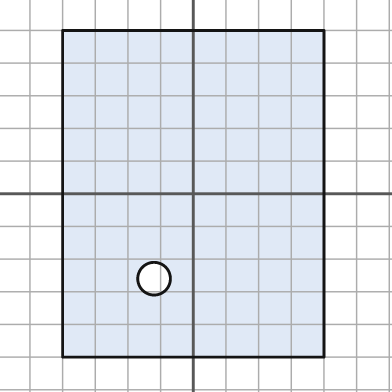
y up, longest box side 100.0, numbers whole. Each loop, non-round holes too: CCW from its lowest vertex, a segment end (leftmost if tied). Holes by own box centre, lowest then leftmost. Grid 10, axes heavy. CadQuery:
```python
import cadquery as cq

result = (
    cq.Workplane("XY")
    .moveTo(-40.0, -50.0)
    .lineTo(40.0, -50.0)
    .lineTo(40.0, 50.0)
    .lineTo(-40.0, 50.0)
    .close()
    .moveTo(-12.0, -26.0)
    .circle(5.0)
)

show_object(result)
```